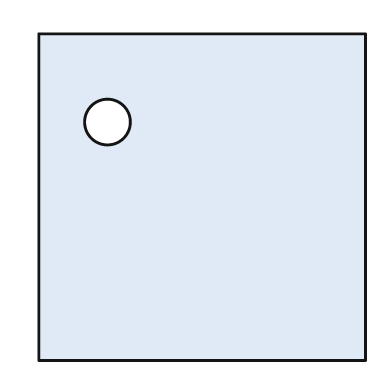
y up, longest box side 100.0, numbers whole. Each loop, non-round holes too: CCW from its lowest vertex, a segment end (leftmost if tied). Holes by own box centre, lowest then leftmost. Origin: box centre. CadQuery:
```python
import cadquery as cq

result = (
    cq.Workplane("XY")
    .moveTo(-50.0, -50.0)
    .lineTo(50.0, -50.0)
    .lineTo(50.0, 50.0)
    .lineTo(-50.0, 50.0)
    .close()
    .moveTo(-29.0, 23.0)
    .circle(7.0)
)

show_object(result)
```